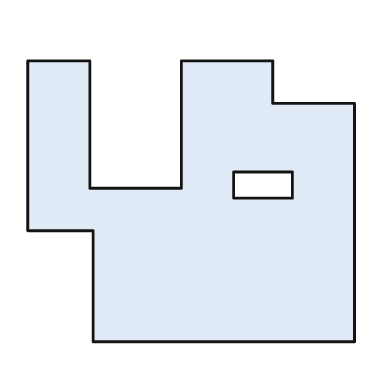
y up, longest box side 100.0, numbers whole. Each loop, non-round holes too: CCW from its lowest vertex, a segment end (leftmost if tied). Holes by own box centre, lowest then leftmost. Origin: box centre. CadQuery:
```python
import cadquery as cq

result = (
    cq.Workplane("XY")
    .moveTo(-30.0, -43.0)
    .lineTo(50.0, -43.0)
    .lineTo(50.0, 30.0)
    .lineTo(25.0, 30.0)
    .lineTo(25.0, 43.0)
    .lineTo(-3.0, 43.0)
    .lineTo(-3.0, 4.0)
    .lineTo(-31.0, 4.0)
    .lineTo(-31.0, 43.0)
    .lineTo(-50.0, 43.0)
    .lineTo(-50.0, -9.0)
    .lineTo(-30.0, -9.0)
    .close()
    .moveTo(13.0, 1.0)
    .lineTo(31.0, 1.0)
    .lineTo(31.0, 9.0)
    .lineTo(13.0, 9.0)
    .close()
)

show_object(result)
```